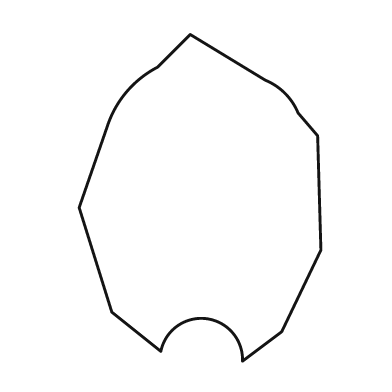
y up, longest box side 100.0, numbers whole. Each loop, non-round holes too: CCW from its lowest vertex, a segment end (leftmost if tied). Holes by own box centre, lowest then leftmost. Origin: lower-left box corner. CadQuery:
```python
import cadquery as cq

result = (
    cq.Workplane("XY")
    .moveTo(50.0, 0.0)
    .lineTo(62.0, 9.0)
    .lineTo(74.0, 34.0)
    .lineTo(73.0, 69.0)
    .lineTo(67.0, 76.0)
    .threePointArc((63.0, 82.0), (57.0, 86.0))
    .lineTo(34.0, 100.0)
    .lineTo(24.0, 90.0)
    .threePointArc((15.0, 83.0), (9.0, 73.0))
    .lineTo(0.0, 47.0)
    .lineTo(10.0, 15.0)
    .lineTo(25.0, 3.0)
    .threePointArc((39.0, 13.0), (50.0, 0.0))
    .close()
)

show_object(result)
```